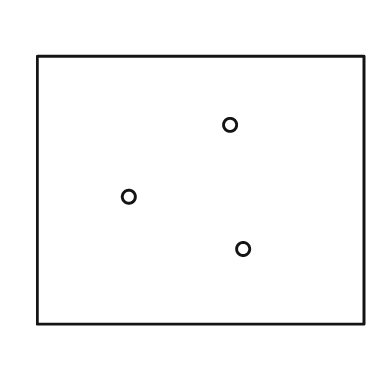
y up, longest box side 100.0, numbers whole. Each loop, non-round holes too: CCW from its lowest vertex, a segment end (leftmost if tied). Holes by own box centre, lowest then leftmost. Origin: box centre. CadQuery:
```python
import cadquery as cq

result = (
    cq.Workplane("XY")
    .moveTo(-50.0, -41.0)
    .lineTo(50.0, -41.0)
    .lineTo(50.0, 41.0)
    .lineTo(-50.0, 41.0)
    .close()
    .moveTo(13.0, -18.0)
    .circle(2.0)
    .moveTo(-22.0, -2.0)
    .circle(2.0)
    .moveTo(9.0, 20.0)
    .circle(2.0)
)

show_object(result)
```